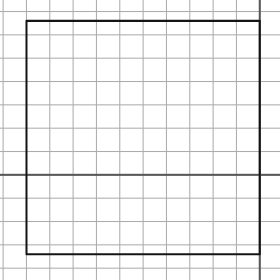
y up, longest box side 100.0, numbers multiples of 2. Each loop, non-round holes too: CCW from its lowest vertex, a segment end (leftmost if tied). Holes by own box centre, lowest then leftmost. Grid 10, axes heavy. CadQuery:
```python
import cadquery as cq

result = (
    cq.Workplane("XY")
    .moveTo(-100.0, -34.0)
    .lineTo(0.0, -34.0)
    .lineTo(0.0, 66.0)
    .lineTo(-100.0, 66.0)
    .close()
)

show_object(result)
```